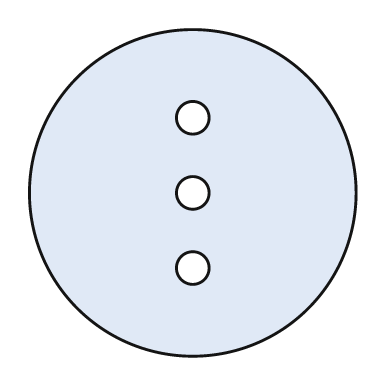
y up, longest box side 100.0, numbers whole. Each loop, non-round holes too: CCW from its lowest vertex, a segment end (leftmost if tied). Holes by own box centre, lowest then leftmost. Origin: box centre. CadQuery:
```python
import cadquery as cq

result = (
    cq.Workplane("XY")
    .moveTo(0.0, 0.0)
    .circle(50.0)
    .moveTo(0.0, -23.0)
    .circle(5.0)
    .moveTo(0.0, 0.0)
    .circle(5.0)
    .moveTo(0.0, 23.0)
    .circle(5.0)
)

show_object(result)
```